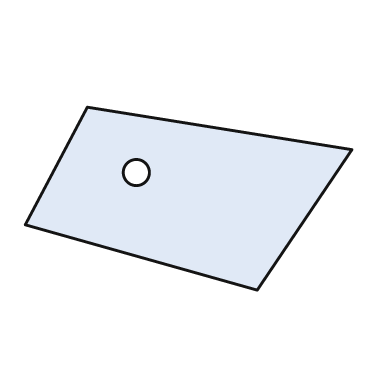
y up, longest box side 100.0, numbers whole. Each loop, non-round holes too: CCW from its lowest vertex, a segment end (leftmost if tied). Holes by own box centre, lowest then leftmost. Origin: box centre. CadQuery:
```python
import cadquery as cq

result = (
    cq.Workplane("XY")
    .moveTo(21.0, -28.0)
    .lineTo(50.0, 15.0)
    .lineTo(-31.0, 28.0)
    .lineTo(-50.0, -8.0)
    .close()
    .moveTo(-16.0, 8.0)
    .circle(4.0)
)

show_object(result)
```